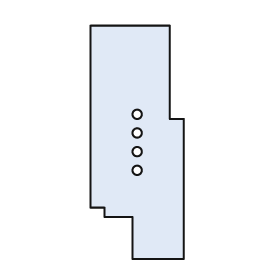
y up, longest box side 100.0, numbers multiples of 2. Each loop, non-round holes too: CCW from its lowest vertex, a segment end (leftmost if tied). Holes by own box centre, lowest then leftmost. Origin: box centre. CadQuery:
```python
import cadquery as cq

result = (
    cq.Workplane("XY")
    .moveTo(-2.0, -50.0)
    .lineTo(20.0, -50.0)
    .lineTo(20.0, 10.0)
    .lineTo(14.0, 10.0)
    .lineTo(14.0, 50.0)
    .lineTo(-20.0, 50.0)
    .lineTo(-20.0, -28.0)
    .lineTo(-14.0, -28.0)
    .lineTo(-14.0, -32.0)
    .lineTo(-2.0, -32.0)
    .close()
    .moveTo(0.0, -12.0)
    .circle(2.0)
    .moveTo(0.0, -4.0)
    .circle(2.0)
    .moveTo(0.0, 4.0)
    .circle(2.0)
    .moveTo(0.0, 12.0)
    .circle(2.0)
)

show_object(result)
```